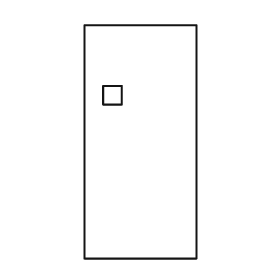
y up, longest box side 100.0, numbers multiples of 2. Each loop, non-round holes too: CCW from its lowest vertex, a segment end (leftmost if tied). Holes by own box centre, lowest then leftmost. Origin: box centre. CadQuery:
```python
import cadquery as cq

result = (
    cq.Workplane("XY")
    .moveTo(-24.0, -50.0)
    .lineTo(24.0, -50.0)
    .lineTo(24.0, 50.0)
    .lineTo(-24.0, 50.0)
    .close()
    .moveTo(-16.0, 16.0)
    .lineTo(-8.0, 16.0)
    .lineTo(-8.0, 24.0)
    .lineTo(-16.0, 24.0)
    .close()
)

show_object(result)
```